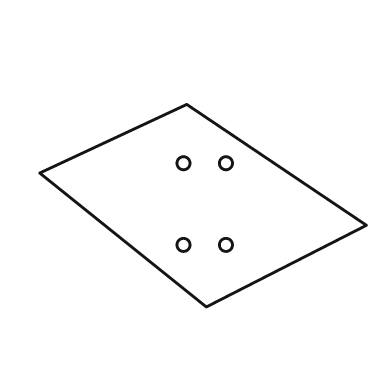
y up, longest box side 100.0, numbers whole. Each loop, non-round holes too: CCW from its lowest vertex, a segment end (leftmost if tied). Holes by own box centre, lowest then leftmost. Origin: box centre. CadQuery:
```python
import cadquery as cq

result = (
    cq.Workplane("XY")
    .moveTo(1.0, -31.0)
    .lineTo(50.0, -6.0)
    .lineTo(-5.0, 31.0)
    .lineTo(-50.0, 10.0)
    .close()
    .moveTo(-6.0, -12.0)
    .circle(2.0)
    .moveTo(7.0, -12.0)
    .circle(2.0)
    .moveTo(-6.0, 13.0)
    .circle(2.0)
    .moveTo(7.0, 13.0)
    .circle(2.0)
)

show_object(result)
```